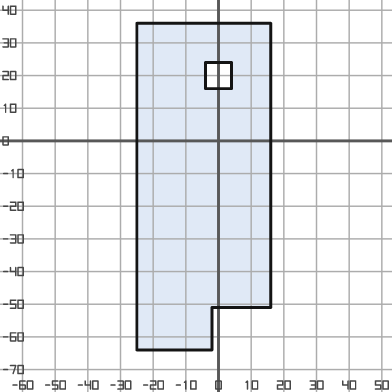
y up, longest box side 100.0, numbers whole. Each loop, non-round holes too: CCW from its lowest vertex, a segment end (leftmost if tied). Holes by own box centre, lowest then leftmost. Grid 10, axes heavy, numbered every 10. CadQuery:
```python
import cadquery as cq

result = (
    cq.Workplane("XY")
    .moveTo(-25.0, -64.0)
    .lineTo(-2.0, -64.0)
    .lineTo(-2.0, -51.0)
    .lineTo(16.0, -51.0)
    .lineTo(16.0, 36.0)
    .lineTo(-25.0, 36.0)
    .close()
    .moveTo(-4.0, 16.0)
    .lineTo(4.0, 16.0)
    .lineTo(4.0, 24.0)
    .lineTo(-4.0, 24.0)
    .close()
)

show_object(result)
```